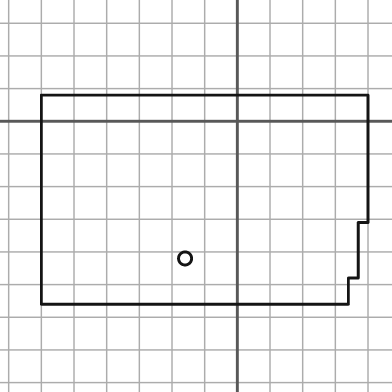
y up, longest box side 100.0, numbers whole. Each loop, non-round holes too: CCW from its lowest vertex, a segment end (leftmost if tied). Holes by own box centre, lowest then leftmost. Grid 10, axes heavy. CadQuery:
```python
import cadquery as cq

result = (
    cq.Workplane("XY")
    .moveTo(-60.0, -56.0)
    .lineTo(34.0, -56.0)
    .lineTo(34.0, -48.0)
    .lineTo(37.0, -48.0)
    .lineTo(37.0, -31.0)
    .lineTo(40.0, -31.0)
    .lineTo(40.0, 8.0)
    .lineTo(-60.0, 8.0)
    .close()
    .moveTo(-16.0, -42.0)
    .circle(2.0)
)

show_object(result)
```